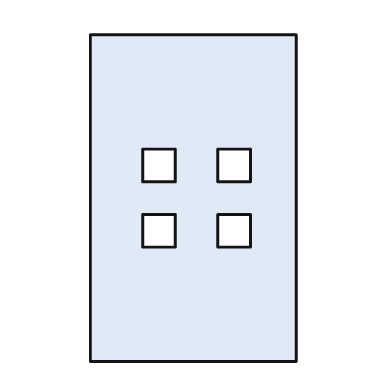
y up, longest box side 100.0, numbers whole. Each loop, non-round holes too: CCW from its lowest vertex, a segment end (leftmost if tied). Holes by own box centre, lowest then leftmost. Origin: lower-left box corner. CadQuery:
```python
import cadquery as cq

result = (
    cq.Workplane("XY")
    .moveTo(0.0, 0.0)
    .lineTo(63.0, 0.0)
    .lineTo(63.0, 100.0)
    .lineTo(0.0, 100.0)
    .close()
    .moveTo(16.0, 35.0)
    .lineTo(26.0, 35.0)
    .lineTo(26.0, 45.0)
    .lineTo(16.0, 45.0)
    .close()
    .moveTo(39.0, 35.0)
    .lineTo(49.0, 35.0)
    .lineTo(49.0, 45.0)
    .lineTo(39.0, 45.0)
    .close()
    .moveTo(16.0, 55.0)
    .lineTo(26.0, 55.0)
    .lineTo(26.0, 65.0)
    .lineTo(16.0, 65.0)
    .close()
    .moveTo(39.0, 55.0)
    .lineTo(49.0, 55.0)
    .lineTo(49.0, 65.0)
    .lineTo(39.0, 65.0)
    .close()
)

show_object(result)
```